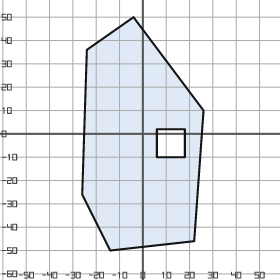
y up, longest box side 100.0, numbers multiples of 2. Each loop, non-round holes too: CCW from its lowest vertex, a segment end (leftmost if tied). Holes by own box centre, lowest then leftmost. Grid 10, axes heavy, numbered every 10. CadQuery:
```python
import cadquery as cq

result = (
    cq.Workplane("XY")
    .moveTo(-14.0, -50.0)
    .lineTo(22.0, -46.0)
    .lineTo(26.0, 10.0)
    .lineTo(-4.0, 50.0)
    .lineTo(-24.0, 36.0)
    .lineTo(-26.0, -26.0)
    .close()
    .moveTo(6.0, -10.0)
    .lineTo(18.0, -10.0)
    .lineTo(18.0, 2.0)
    .lineTo(6.0, 2.0)
    .close()
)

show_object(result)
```